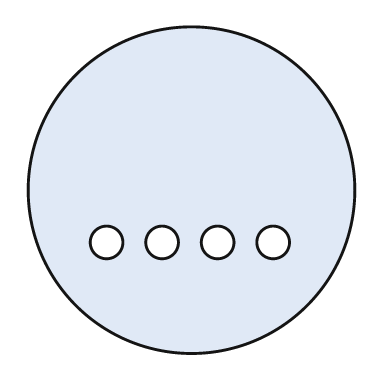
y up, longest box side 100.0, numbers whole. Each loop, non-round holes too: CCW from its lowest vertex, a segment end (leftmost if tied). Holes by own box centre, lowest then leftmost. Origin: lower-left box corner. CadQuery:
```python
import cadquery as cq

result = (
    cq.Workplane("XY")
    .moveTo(50.0, 50.0)
    .circle(50.0)
    .moveTo(24.0, 34.0)
    .circle(5.0)
    .moveTo(41.0, 34.0)
    .circle(5.0)
    .moveTo(58.0, 34.0)
    .circle(5.0)
    .moveTo(75.0, 34.0)
    .circle(5.0)
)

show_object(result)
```